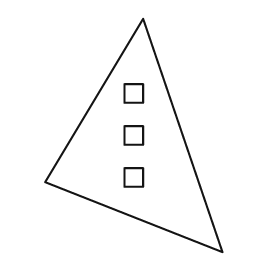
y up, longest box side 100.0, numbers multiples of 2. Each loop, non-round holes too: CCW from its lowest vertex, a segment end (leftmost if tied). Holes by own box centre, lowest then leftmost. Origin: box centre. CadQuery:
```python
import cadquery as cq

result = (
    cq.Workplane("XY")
    .moveTo(38.0, -50.0)
    .lineTo(4.0, 50.0)
    .lineTo(-38.0, -20.0)
    .close()
    .moveTo(-4.0, -22.0)
    .lineTo(4.0, -22.0)
    .lineTo(4.0, -14.0)
    .lineTo(-4.0, -14.0)
    .close()
    .moveTo(-4.0, -4.0)
    .lineTo(4.0, -4.0)
    .lineTo(4.0, 4.0)
    .lineTo(-4.0, 4.0)
    .close()
    .moveTo(-4.0, 14.0)
    .lineTo(4.0, 14.0)
    .lineTo(4.0, 22.0)
    .lineTo(-4.0, 22.0)
    .close()
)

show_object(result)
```